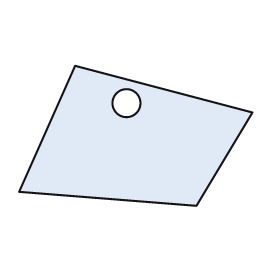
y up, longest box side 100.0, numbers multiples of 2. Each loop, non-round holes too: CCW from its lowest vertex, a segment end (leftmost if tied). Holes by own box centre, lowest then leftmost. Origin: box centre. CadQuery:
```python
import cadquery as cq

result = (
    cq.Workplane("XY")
    .moveTo(26.0, -30.0)
    .lineTo(50.0, 10.0)
    .lineTo(-26.0, 30.0)
    .lineTo(-50.0, -24.0)
    .close()
    .moveTo(-4.0, 14.0)
    .circle(6.0)
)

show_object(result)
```